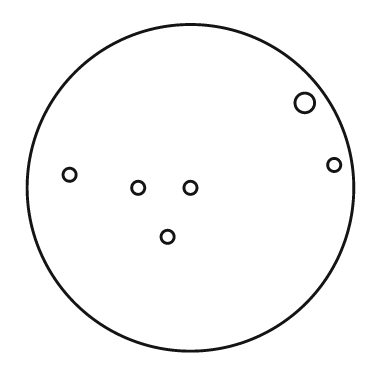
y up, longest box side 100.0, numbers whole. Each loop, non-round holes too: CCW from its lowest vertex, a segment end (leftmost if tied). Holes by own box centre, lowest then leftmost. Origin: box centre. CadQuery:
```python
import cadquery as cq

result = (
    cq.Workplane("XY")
    .moveTo(0.0, 0.0)
    .circle(50.0)
    .moveTo(-7.0, -15.0)
    .circle(2.0)
    .moveTo(-16.0, 0.0)
    .circle(2.0)
    .moveTo(0.0, 0.0)
    .circle(2.0)
    .moveTo(-37.0, 4.0)
    .circle(2.0)
    .moveTo(44.0, 7.0)
    .circle(2.0)
    .moveTo(35.0, 26.0)
    .circle(3.0)
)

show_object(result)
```